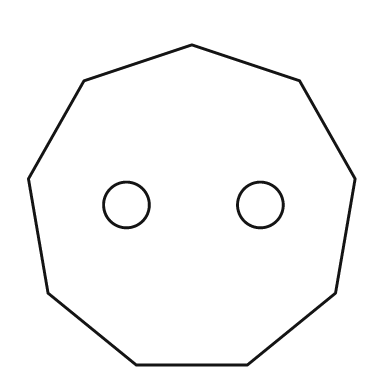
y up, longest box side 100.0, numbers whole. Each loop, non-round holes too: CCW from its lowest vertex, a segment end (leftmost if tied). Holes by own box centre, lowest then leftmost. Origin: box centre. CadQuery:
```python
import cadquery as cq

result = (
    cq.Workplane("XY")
    .moveTo(-17.0, -49.0)
    .lineTo(17.0, -49.0)
    .lineTo(44.0, -27.0)
    .lineTo(50.0, 8.0)
    .lineTo(33.0, 38.0)
    .lineTo(0.0, 49.0)
    .lineTo(-33.0, 38.0)
    .lineTo(-50.0, 8.0)
    .lineTo(-44.0, -27.0)
    .close()
    .moveTo(-20.0, 0.0)
    .circle(7.0)
    .moveTo(21.0, 0.0)
    .circle(7.0)
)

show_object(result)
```